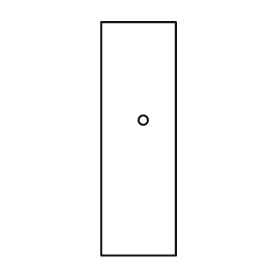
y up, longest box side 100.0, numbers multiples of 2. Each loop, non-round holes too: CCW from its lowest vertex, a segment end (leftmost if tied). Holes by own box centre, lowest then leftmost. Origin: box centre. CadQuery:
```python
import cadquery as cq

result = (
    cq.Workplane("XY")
    .moveTo(-16.0, -50.0)
    .lineTo(16.0, -50.0)
    .lineTo(16.0, 50.0)
    .lineTo(-16.0, 50.0)
    .close()
    .moveTo(2.0, 8.0)
    .circle(2.0)
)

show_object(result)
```